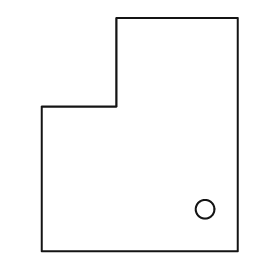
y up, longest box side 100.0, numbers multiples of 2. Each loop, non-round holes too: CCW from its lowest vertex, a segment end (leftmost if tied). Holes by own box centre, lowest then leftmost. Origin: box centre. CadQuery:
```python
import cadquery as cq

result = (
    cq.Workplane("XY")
    .moveTo(-42.0, -50.0)
    .lineTo(42.0, -50.0)
    .lineTo(42.0, 50.0)
    .lineTo(-10.0, 50.0)
    .lineTo(-10.0, 12.0)
    .lineTo(-42.0, 12.0)
    .close()
    .moveTo(28.0, -32.0)
    .circle(4.0)
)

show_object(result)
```